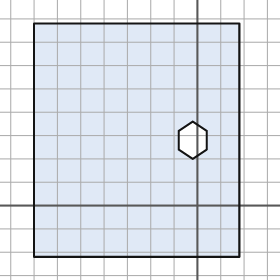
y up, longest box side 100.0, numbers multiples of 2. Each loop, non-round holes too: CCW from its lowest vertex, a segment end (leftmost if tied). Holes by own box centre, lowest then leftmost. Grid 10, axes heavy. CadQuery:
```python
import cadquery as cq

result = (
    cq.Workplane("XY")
    .moveTo(-70.0, -22.0)
    .lineTo(18.0, -22.0)
    .lineTo(18.0, 78.0)
    .lineTo(-70.0, 78.0)
    .close()
    .moveTo(-2.0, 20.0)
    .lineTo(4.0, 24.0)
    .lineTo(4.0, 32.0)
    .lineTo(-2.0, 36.0)
    .lineTo(-8.0, 32.0)
    .lineTo(-8.0, 24.0)
    .close()
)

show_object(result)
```